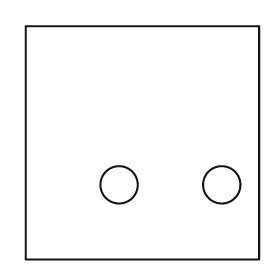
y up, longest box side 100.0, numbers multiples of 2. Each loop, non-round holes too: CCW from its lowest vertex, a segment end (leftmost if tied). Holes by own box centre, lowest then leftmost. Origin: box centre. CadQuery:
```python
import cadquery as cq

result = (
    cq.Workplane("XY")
    .moveTo(-50.0, -50.0)
    .lineTo(50.0, -50.0)
    .lineTo(50.0, 50.0)
    .lineTo(-50.0, 50.0)
    .close()
    .moveTo(-10.0, -18.0)
    .circle(8.0)
    .moveTo(34.0, -18.0)
    .circle(8.0)
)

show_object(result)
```